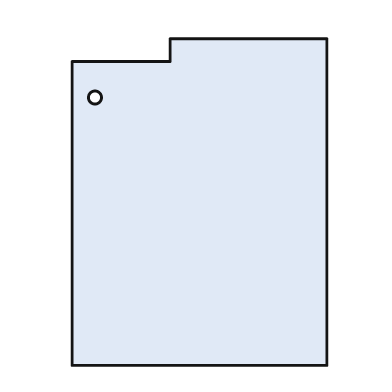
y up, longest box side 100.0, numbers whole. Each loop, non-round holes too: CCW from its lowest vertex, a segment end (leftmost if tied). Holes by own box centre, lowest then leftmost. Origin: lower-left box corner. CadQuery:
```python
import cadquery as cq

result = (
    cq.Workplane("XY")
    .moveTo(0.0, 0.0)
    .lineTo(78.0, 0.0)
    .lineTo(78.0, 100.0)
    .lineTo(30.0, 100.0)
    .lineTo(30.0, 93.0)
    .lineTo(0.0, 93.0)
    .close()
    .moveTo(7.0, 82.0)
    .circle(2.0)
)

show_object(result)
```